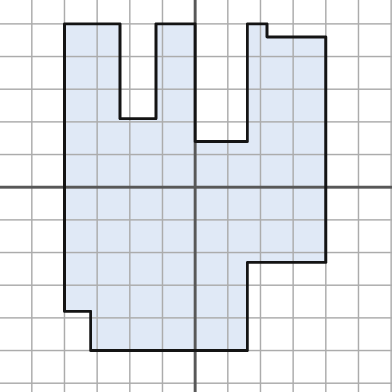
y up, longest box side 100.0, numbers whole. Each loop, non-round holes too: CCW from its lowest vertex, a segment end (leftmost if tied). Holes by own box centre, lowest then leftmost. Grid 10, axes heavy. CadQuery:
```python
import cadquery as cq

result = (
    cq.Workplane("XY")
    .moveTo(-32.0, -50.0)
    .lineTo(16.0, -50.0)
    .lineTo(16.0, -23.0)
    .lineTo(40.0, -23.0)
    .lineTo(40.0, 46.0)
    .lineTo(22.0, 46.0)
    .lineTo(22.0, 50.0)
    .lineTo(16.0, 50.0)
    .lineTo(16.0, 14.0)
    .lineTo(0.0, 14.0)
    .lineTo(0.0, 50.0)
    .lineTo(-12.0, 50.0)
    .lineTo(-12.0, 21.0)
    .lineTo(-23.0, 21.0)
    .lineTo(-23.0, 50.0)
    .lineTo(-40.0, 50.0)
    .lineTo(-40.0, -38.0)
    .lineTo(-32.0, -38.0)
    .close()
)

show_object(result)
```